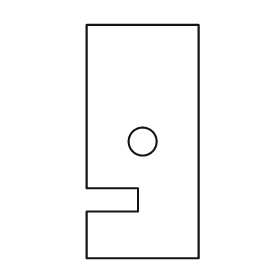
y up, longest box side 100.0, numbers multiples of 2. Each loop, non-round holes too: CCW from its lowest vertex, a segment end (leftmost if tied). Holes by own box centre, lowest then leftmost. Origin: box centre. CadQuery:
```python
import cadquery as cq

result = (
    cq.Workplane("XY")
    .moveTo(-24.0, -50.0)
    .lineTo(24.0, -50.0)
    .lineTo(24.0, 50.0)
    .lineTo(-24.0, 50.0)
    .lineTo(-24.0, -20.0)
    .lineTo(-2.0, -20.0)
    .lineTo(-2.0, -30.0)
    .lineTo(-24.0, -30.0)
    .close()
    .moveTo(0.0, 0.0)
    .circle(6.0)
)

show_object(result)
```